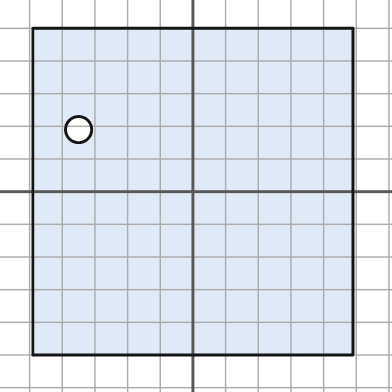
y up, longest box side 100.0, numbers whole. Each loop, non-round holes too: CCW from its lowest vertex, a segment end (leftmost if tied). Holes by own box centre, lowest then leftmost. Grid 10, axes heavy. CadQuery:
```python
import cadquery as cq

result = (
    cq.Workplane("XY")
    .moveTo(-49.0, -50.0)
    .lineTo(49.0, -50.0)
    .lineTo(49.0, 50.0)
    .lineTo(-49.0, 50.0)
    .close()
    .moveTo(-35.0, 19.0)
    .circle(4.0)
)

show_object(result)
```